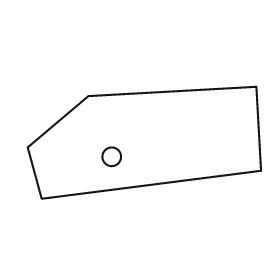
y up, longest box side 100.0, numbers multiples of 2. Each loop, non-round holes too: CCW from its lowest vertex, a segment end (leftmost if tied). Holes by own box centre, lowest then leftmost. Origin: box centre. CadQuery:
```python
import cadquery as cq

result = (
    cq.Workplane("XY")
    .moveTo(-44.0, -24.0)
    .lineTo(50.0, -12.0)
    .lineTo(48.0, 24.0)
    .lineTo(-24.0, 20.0)
    .lineTo(-50.0, -2.0)
    .close()
    .moveTo(-14.0, -6.0)
    .circle(4.0)
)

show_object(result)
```